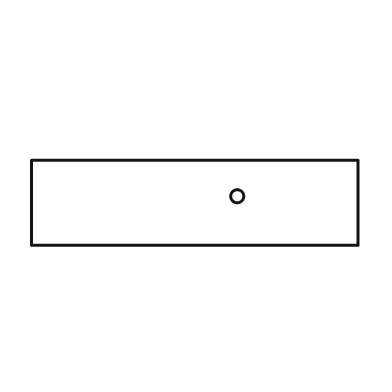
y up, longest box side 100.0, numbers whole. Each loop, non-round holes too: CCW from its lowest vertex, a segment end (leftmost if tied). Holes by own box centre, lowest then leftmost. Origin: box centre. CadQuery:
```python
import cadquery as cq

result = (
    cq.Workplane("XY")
    .moveTo(-50.0, -13.0)
    .lineTo(50.0, -13.0)
    .lineTo(50.0, 13.0)
    .lineTo(-50.0, 13.0)
    .close()
    .moveTo(13.0, 2.0)
    .circle(2.0)
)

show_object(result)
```